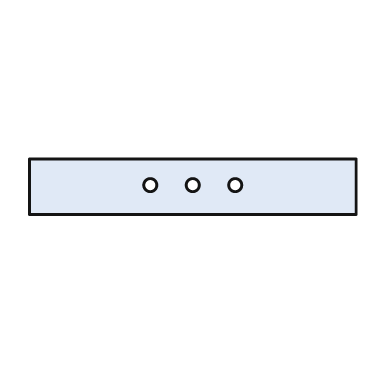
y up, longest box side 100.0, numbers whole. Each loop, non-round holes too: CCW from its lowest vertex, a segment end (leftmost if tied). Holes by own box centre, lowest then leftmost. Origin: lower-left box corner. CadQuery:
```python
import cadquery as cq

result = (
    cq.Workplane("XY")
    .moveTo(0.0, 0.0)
    .lineTo(100.0, 0.0)
    .lineTo(100.0, 17.0)
    .lineTo(0.0, 17.0)
    .close()
    .moveTo(37.0, 9.0)
    .circle(2.0)
    .moveTo(50.0, 9.0)
    .circle(2.0)
    .moveTo(63.0, 9.0)
    .circle(2.0)
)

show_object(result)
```